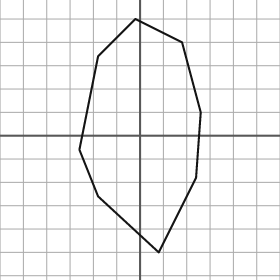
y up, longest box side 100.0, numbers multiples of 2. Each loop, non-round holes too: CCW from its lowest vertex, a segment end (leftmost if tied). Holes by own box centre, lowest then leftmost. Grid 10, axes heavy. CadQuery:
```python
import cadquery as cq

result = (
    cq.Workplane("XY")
    .moveTo(8.0, -50.0)
    .lineTo(24.0, -18.0)
    .lineTo(26.0, 10.0)
    .lineTo(18.0, 40.0)
    .lineTo(-2.0, 50.0)
    .lineTo(-18.0, 34.0)
    .lineTo(-26.0, -6.0)
    .lineTo(-18.0, -26.0)
    .close()
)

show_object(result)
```